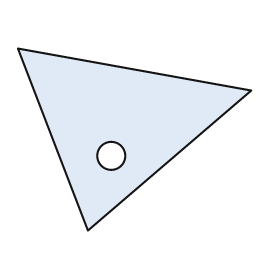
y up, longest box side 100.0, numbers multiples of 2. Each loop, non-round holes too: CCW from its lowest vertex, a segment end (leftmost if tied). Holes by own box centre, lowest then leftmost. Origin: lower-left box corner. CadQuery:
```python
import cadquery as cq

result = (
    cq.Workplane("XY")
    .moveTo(30.0, 0.0)
    .lineTo(100.0, 60.0)
    .lineTo(0.0, 78.0)
    .close()
    .moveTo(40.0, 32.0)
    .circle(6.0)
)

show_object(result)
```